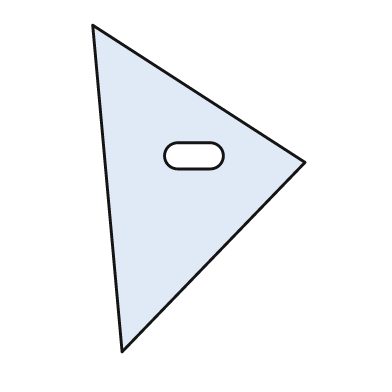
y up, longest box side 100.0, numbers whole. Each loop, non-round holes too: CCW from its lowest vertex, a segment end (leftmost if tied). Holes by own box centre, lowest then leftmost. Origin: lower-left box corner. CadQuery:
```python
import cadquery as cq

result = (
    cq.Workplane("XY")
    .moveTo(9.0, 0.0)
    .lineTo(65.0, 58.0)
    .lineTo(0.0, 100.0)
    .close()
    .moveTo(26.0, 56.0)
    .lineTo(36.0, 56.0)
    .threePointArc((40.0, 60.0), (36.0, 64.0))
    .lineTo(26.0, 64.0)
    .threePointArc((22.0, 60.0), (26.0, 56.0))
    .close()
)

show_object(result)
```